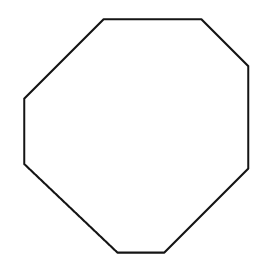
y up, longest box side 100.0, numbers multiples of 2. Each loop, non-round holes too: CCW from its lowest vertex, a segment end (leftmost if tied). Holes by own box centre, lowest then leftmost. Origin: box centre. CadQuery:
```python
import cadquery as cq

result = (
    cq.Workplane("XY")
    .moveTo(-8.0, -50.0)
    .lineTo(12.0, -50.0)
    .lineTo(48.0, -14.0)
    .lineTo(48.0, 30.0)
    .lineTo(28.0, 50.0)
    .lineTo(-14.0, 50.0)
    .lineTo(-48.0, 16.0)
    .lineTo(-48.0, -12.0)
    .close()
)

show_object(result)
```